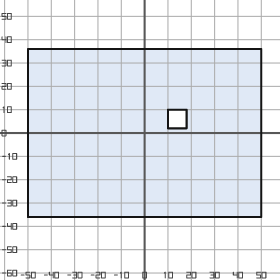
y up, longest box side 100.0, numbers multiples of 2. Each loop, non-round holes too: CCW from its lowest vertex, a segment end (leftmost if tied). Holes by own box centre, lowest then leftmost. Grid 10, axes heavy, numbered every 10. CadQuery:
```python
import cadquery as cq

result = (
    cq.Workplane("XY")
    .moveTo(-50.0, -36.0)
    .lineTo(50.0, -36.0)
    .lineTo(50.0, 36.0)
    .lineTo(-50.0, 36.0)
    .close()
    .moveTo(10.0, 2.0)
    .lineTo(18.0, 2.0)
    .lineTo(18.0, 10.0)
    .lineTo(10.0, 10.0)
    .close()
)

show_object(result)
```